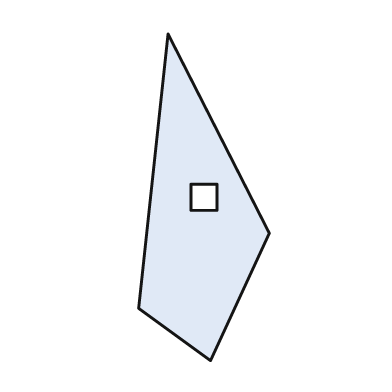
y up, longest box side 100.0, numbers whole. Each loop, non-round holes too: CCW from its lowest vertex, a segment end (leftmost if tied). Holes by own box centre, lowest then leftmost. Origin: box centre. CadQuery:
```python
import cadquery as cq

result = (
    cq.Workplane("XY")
    .moveTo(2.0, -50.0)
    .lineTo(20.0, -11.0)
    .lineTo(-11.0, 50.0)
    .lineTo(-20.0, -34.0)
    .close()
    .moveTo(-4.0, -4.0)
    .lineTo(4.0, -4.0)
    .lineTo(4.0, 4.0)
    .lineTo(-4.0, 4.0)
    .close()
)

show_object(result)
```